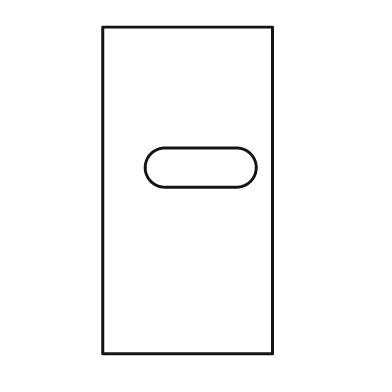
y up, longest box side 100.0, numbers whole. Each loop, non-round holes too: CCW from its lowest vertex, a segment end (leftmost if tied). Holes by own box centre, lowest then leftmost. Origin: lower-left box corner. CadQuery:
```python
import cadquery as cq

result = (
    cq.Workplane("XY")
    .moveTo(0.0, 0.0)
    .lineTo(52.0, 0.0)
    .lineTo(52.0, 100.0)
    .lineTo(0.0, 100.0)
    .close()
    .moveTo(19.0, 51.0)
    .lineTo(41.0, 51.0)
    .threePointArc((47.0, 57.0), (41.0, 63.0))
    .lineTo(19.0, 63.0)
    .threePointArc((13.0, 57.0), (19.0, 51.0))
    .close()
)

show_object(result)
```